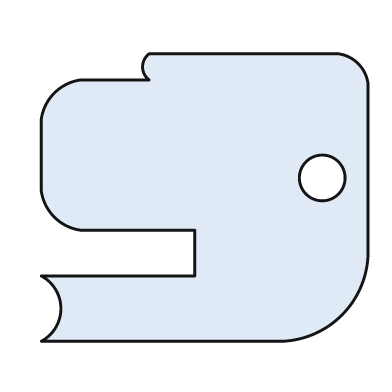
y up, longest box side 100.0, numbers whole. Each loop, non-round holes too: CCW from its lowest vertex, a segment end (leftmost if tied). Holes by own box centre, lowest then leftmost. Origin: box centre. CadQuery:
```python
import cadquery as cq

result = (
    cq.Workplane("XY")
    .moveTo(-50.0, -44.0)
    .lineTo(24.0, -44.0)
    .threePointArc((42.0, -36.0), (50.0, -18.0))
    .lineTo(50.0, 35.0)
    .threePointArc((47.0, 41.0), (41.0, 44.0))
    .lineTo(-17.0, 44.0)
    .threePointArc((-19.0, 40.0), (-17.0, 36.0))
    .lineTo(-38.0, 36.0)
    .threePointArc((-46.0, 32.0), (-50.0, 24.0))
    .lineTo(-50.0, 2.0)
    .threePointArc((-46.0, -6.0), (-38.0, -10.0))
    .lineTo(-3.0, -10.0)
    .lineTo(-3.0, -24.0)
    .lineTo(-50.0, -24.0)
    .threePointArc((-44.0, -34.0), (-50.0, -44.0))
    .close()
    .moveTo(36.0, 6.0)
    .circle(7.0)
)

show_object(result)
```